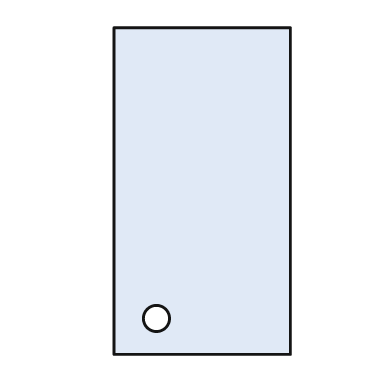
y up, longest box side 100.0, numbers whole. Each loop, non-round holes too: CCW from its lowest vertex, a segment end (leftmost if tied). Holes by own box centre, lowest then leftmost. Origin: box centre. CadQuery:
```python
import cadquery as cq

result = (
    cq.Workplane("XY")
    .moveTo(-27.0, -50.0)
    .lineTo(27.0, -50.0)
    .lineTo(27.0, 50.0)
    .lineTo(-27.0, 50.0)
    .close()
    .moveTo(-14.0, -39.0)
    .circle(4.0)
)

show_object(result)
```